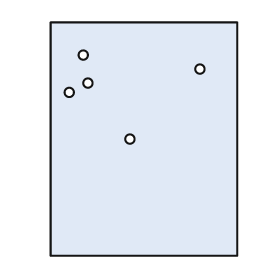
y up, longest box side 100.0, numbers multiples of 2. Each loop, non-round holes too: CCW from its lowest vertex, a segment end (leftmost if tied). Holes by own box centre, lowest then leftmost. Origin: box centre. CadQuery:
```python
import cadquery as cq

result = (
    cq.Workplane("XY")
    .moveTo(-40.0, -50.0)
    .lineTo(40.0, -50.0)
    .lineTo(40.0, 50.0)
    .lineTo(-40.0, 50.0)
    .close()
    .moveTo(-6.0, 0.0)
    .circle(2.0)
    .moveTo(-32.0, 20.0)
    .circle(2.0)
    .moveTo(-24.0, 24.0)
    .circle(2.0)
    .moveTo(24.0, 30.0)
    .circle(2.0)
    .moveTo(-26.0, 36.0)
    .circle(2.0)
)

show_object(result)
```